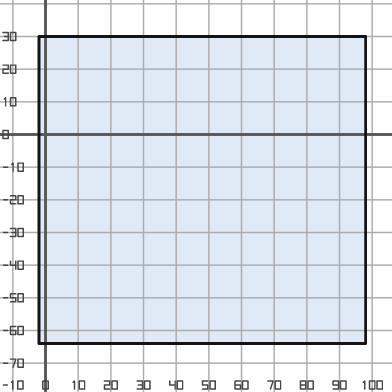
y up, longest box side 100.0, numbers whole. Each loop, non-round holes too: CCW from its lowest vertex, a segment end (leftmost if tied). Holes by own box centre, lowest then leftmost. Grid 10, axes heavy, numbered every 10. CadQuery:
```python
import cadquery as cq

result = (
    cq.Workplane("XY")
    .moveTo(-2.0, -64.0)
    .lineTo(98.0, -64.0)
    .lineTo(98.0, 30.0)
    .lineTo(-2.0, 30.0)
    .close()
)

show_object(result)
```